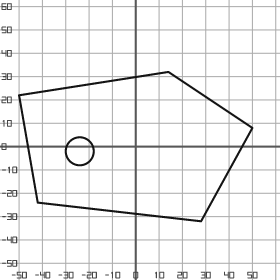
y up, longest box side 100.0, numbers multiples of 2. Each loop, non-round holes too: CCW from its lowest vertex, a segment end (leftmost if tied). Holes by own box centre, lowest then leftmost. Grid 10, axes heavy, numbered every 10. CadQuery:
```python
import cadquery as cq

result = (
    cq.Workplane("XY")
    .moveTo(28.0, -32.0)
    .lineTo(50.0, 8.0)
    .lineTo(14.0, 32.0)
    .lineTo(-50.0, 22.0)
    .lineTo(-42.0, -24.0)
    .close()
    .moveTo(-24.0, -2.0)
    .circle(6.0)
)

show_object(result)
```